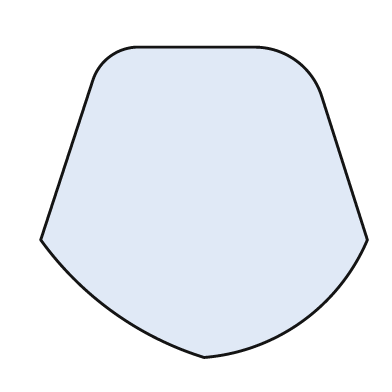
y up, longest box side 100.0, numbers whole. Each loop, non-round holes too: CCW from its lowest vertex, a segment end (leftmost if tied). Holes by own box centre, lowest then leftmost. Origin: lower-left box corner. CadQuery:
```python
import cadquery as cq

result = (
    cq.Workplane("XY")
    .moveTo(50.0, 0.0)
    .threePointArc((80.0, 11.0), (100.0, 36.0))
    .lineTo(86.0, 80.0)
    .threePointArc((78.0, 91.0), (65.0, 95.0))
    .lineTo(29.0, 95.0)
    .threePointArc((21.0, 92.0), (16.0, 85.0))
    .lineTo(0.0, 36.0)
    .threePointArc((22.0, 14.0), (50.0, 0.0))
    .close()
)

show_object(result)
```